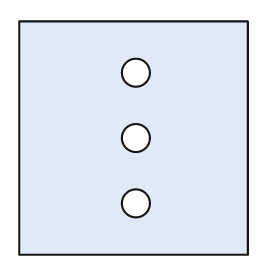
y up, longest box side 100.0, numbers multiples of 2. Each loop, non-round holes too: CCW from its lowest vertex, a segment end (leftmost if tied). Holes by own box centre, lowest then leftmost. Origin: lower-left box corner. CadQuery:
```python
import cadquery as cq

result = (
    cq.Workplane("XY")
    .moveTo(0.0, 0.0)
    .lineTo(98.0, 0.0)
    .lineTo(98.0, 100.0)
    .lineTo(0.0, 100.0)
    .close()
    .moveTo(50.0, 22.0)
    .circle(6.0)
    .moveTo(50.0, 50.0)
    .circle(6.0)
    .moveTo(50.0, 78.0)
    .circle(6.0)
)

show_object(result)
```